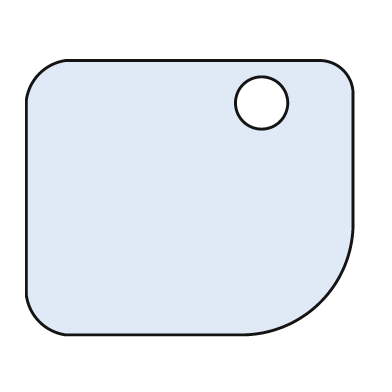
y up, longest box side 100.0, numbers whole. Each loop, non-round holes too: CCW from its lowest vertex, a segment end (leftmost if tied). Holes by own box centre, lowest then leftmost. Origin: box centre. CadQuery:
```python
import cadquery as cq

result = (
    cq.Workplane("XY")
    .moveTo(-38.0, -42.0)
    .lineTo(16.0, -42.0)
    .threePointArc((40.0, -32.0), (50.0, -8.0))
    .lineTo(50.0, 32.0)
    .threePointArc((47.0, 39.0), (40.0, 42.0))
    .lineTo(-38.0, 42.0)
    .threePointArc((-46.0, 38.0), (-50.0, 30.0))
    .lineTo(-50.0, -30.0)
    .threePointArc((-46.0, -38.0), (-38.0, -42.0))
    .close()
    .moveTo(22.0, 29.0)
    .circle(8.0)
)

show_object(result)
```